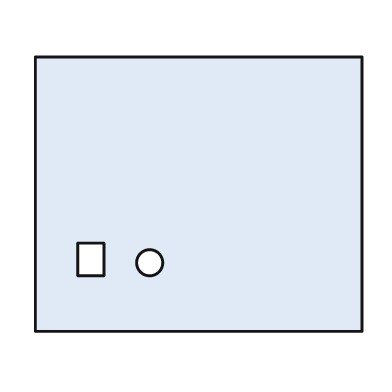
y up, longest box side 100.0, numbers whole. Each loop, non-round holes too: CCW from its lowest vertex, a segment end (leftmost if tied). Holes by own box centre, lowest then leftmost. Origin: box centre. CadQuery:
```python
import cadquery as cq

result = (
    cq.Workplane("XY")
    .moveTo(-50.0, -42.0)
    .lineTo(50.0, -42.0)
    .lineTo(50.0, 42.0)
    .lineTo(-50.0, 42.0)
    .close()
    .moveTo(-15.0, -21.0)
    .circle(4.0)
    .moveTo(-37.0, -25.0)
    .lineTo(-29.0, -25.0)
    .lineTo(-29.0, -15.0)
    .lineTo(-37.0, -15.0)
    .close()
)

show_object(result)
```